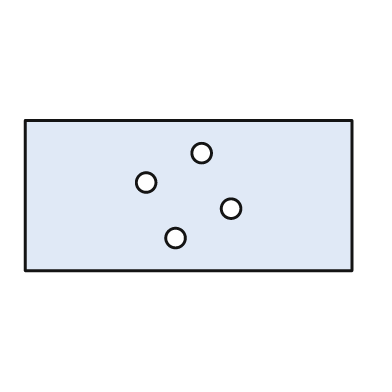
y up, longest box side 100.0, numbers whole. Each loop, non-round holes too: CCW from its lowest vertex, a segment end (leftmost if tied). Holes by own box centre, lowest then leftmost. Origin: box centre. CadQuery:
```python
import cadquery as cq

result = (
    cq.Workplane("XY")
    .moveTo(-50.0, -23.0)
    .lineTo(50.0, -23.0)
    .lineTo(50.0, 23.0)
    .lineTo(-50.0, 23.0)
    .close()
    .moveTo(-4.0, -13.0)
    .circle(3.0)
    .moveTo(13.0, -4.0)
    .circle(3.0)
    .moveTo(-13.0, 4.0)
    .circle(3.0)
    .moveTo(4.0, 13.0)
    .circle(3.0)
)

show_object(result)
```